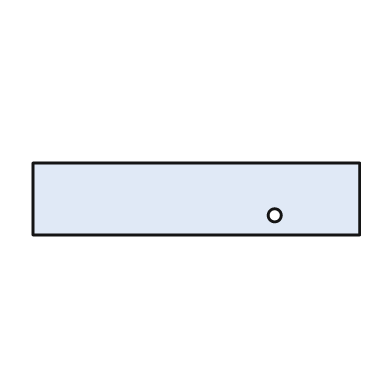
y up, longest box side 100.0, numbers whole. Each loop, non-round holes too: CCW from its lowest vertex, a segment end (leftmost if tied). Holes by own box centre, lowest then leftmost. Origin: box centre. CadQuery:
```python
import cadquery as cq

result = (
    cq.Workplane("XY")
    .moveTo(-50.0, -11.0)
    .lineTo(50.0, -11.0)
    .lineTo(50.0, 11.0)
    .lineTo(-50.0, 11.0)
    .close()
    .moveTo(24.0, -5.0)
    .circle(2.0)
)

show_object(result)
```